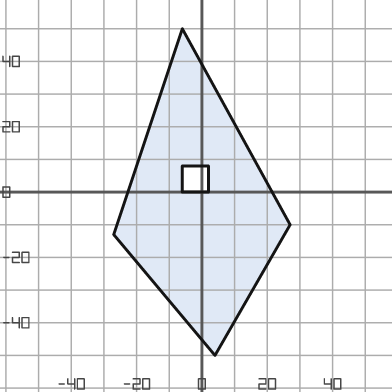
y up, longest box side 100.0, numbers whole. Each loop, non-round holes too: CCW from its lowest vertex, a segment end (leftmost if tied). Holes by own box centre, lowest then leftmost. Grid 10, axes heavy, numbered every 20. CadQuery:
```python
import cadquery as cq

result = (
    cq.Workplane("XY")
    .moveTo(4.0, -50.0)
    .lineTo(27.0, -10.0)
    .lineTo(-6.0, 50.0)
    .lineTo(-27.0, -13.0)
    .close()
    .moveTo(-6.0, 0.0)
    .lineTo(2.0, 0.0)
    .lineTo(2.0, 8.0)
    .lineTo(-6.0, 8.0)
    .close()
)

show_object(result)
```